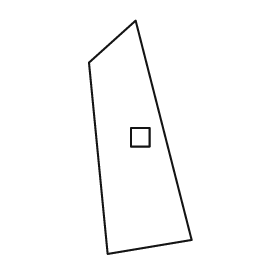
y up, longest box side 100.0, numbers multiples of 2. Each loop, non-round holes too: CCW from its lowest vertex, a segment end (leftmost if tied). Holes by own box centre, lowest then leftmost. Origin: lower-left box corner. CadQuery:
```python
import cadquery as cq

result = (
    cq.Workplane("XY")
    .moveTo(8.0, 0.0)
    .lineTo(44.0, 6.0)
    .lineTo(20.0, 100.0)
    .lineTo(0.0, 82.0)
    .close()
    .moveTo(18.0, 46.0)
    .lineTo(26.0, 46.0)
    .lineTo(26.0, 54.0)
    .lineTo(18.0, 54.0)
    .close()
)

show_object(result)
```